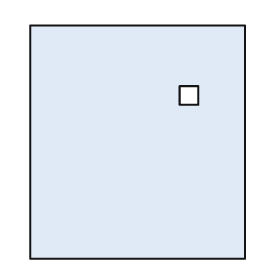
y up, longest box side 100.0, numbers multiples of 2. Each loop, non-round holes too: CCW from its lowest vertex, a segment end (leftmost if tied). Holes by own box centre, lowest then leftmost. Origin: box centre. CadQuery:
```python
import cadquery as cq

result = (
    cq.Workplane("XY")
    .moveTo(-46.0, -50.0)
    .lineTo(46.0, -50.0)
    .lineTo(46.0, 50.0)
    .lineTo(-46.0, 50.0)
    .close()
    .moveTo(18.0, 16.0)
    .lineTo(26.0, 16.0)
    .lineTo(26.0, 24.0)
    .lineTo(18.0, 24.0)
    .close()
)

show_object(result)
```